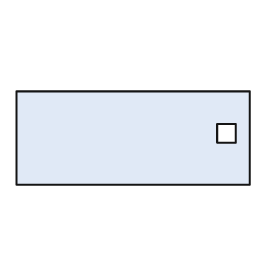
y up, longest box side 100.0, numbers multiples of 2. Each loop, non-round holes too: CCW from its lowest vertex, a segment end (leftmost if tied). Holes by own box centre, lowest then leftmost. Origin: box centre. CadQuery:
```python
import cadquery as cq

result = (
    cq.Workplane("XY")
    .moveTo(-50.0, -20.0)
    .lineTo(50.0, -20.0)
    .lineTo(50.0, 20.0)
    .lineTo(-50.0, 20.0)
    .close()
    .moveTo(36.0, -2.0)
    .lineTo(44.0, -2.0)
    .lineTo(44.0, 6.0)
    .lineTo(36.0, 6.0)
    .close()
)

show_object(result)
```